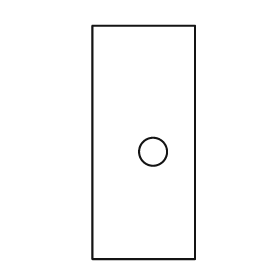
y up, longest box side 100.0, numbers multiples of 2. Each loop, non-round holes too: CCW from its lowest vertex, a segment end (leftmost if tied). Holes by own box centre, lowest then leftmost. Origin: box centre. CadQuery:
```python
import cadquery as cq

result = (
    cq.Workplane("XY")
    .moveTo(-22.0, -50.0)
    .lineTo(22.0, -50.0)
    .lineTo(22.0, 50.0)
    .lineTo(-22.0, 50.0)
    .close()
    .moveTo(4.0, -4.0)
    .circle(6.0)
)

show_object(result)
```